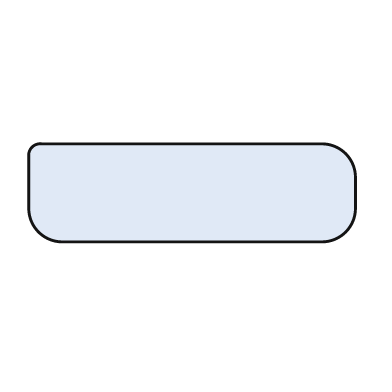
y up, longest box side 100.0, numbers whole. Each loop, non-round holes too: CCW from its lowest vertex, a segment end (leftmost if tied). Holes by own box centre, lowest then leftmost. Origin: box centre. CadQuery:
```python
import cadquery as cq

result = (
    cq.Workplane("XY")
    .moveTo(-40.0, -15.0)
    .lineTo(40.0, -15.0)
    .threePointArc((47.0, -12.0), (50.0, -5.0))
    .lineTo(50.0, 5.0)
    .threePointArc((47.0, 12.0), (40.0, 15.0))
    .lineTo(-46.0, 15.0)
    .threePointArc((-49.0, 14.0), (-50.0, 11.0))
    .lineTo(-50.0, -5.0)
    .threePointArc((-47.0, -12.0), (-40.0, -15.0))
    .close()
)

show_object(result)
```